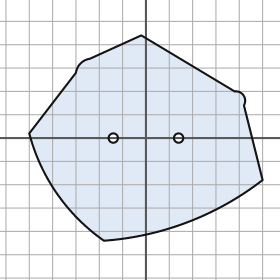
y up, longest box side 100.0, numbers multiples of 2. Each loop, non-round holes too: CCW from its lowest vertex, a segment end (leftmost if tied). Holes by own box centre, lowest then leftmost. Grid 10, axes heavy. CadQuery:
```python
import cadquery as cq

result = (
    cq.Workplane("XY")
    .moveTo(-18.0, -44.0)
    .threePointArc((18.0, -36.0), (50.0, -18.0))
    .lineTo(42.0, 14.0)
    .threePointArc((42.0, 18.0), (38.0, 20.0))
    .lineTo(-2.0, 44.0)
    .lineTo(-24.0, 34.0)
    .threePointArc((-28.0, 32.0), (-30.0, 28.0))
    .lineTo(-50.0, 2.0)
    .threePointArc((-38.0, -24.0), (-18.0, -44.0))
    .close()
    .moveTo(-14.0, 0.0)
    .circle(2.0)
    .moveTo(14.0, 0.0)
    .circle(2.0)
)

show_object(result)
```